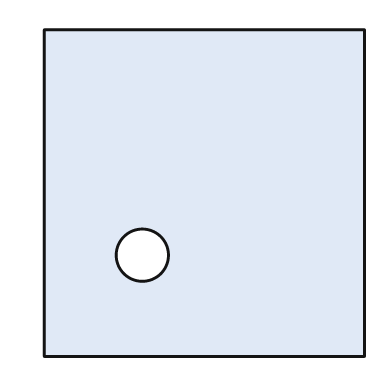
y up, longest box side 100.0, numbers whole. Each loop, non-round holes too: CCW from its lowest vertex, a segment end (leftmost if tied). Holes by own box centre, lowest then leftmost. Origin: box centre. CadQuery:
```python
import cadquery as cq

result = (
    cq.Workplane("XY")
    .moveTo(-49.0, -50.0)
    .lineTo(49.0, -50.0)
    .lineTo(49.0, 50.0)
    .lineTo(-49.0, 50.0)
    .close()
    .moveTo(-19.0, -19.0)
    .circle(8.0)
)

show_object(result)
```